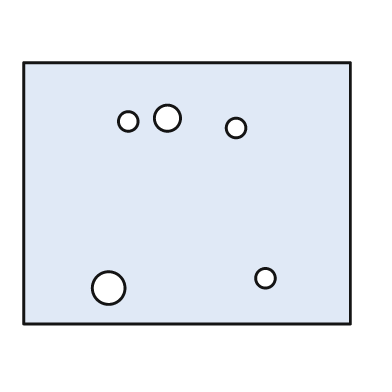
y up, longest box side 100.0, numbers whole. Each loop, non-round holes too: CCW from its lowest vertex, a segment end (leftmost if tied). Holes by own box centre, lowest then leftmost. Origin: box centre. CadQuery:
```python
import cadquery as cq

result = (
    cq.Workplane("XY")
    .moveTo(-50.0, -40.0)
    .lineTo(50.0, -40.0)
    .lineTo(50.0, 40.0)
    .lineTo(-50.0, 40.0)
    .close()
    .moveTo(-24.0, -29.0)
    .circle(5.0)
    .moveTo(24.0, -26.0)
    .circle(3.0)
    .moveTo(15.0, 20.0)
    .circle(3.0)
    .moveTo(-18.0, 22.0)
    .circle(3.0)
    .moveTo(-6.0, 23.0)
    .circle(4.0)
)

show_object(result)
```